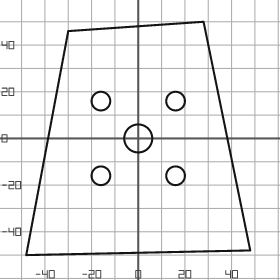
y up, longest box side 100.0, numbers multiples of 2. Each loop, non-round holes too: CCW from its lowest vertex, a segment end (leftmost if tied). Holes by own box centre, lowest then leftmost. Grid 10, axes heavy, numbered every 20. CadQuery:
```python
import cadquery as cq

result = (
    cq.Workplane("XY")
    .moveTo(-48.0, -50.0)
    .lineTo(48.0, -48.0)
    .lineTo(28.0, 50.0)
    .lineTo(-30.0, 46.0)
    .close()
    .moveTo(-16.0, -16.0)
    .circle(4.0)
    .moveTo(16.0, -16.0)
    .circle(4.0)
    .moveTo(0.0, 0.0)
    .circle(6.0)
    .moveTo(-16.0, 16.0)
    .circle(4.0)
    .moveTo(16.0, 16.0)
    .circle(4.0)
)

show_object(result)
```